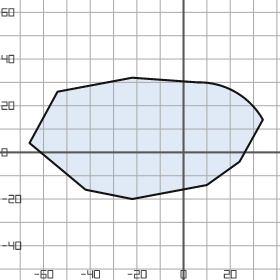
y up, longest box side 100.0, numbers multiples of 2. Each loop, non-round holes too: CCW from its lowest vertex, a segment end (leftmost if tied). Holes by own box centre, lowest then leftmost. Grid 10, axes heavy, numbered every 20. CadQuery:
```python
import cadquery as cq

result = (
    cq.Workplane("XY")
    .moveTo(-22.0, -20.0)
    .lineTo(10.0, -14.0)
    .lineTo(24.0, -4.0)
    .lineTo(34.0, 14.0)
    .threePointArc((22.0, 26.0), (6.0, 30.0))
    .lineTo(-22.0, 32.0)
    .lineTo(-54.0, 26.0)
    .lineTo(-66.0, 4.0)
    .lineTo(-42.0, -16.0)
    .close()
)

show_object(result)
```